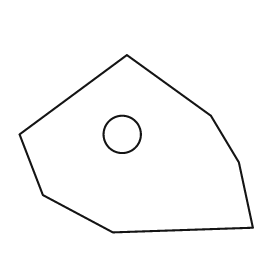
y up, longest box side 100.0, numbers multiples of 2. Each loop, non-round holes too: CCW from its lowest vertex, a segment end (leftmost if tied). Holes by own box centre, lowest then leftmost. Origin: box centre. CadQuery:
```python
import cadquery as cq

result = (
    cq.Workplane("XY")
    .moveTo(-10.0, -38.0)
    .lineTo(50.0, -36.0)
    .lineTo(44.0, -8.0)
    .lineTo(32.0, 12.0)
    .lineTo(-4.0, 38.0)
    .lineTo(-50.0, 4.0)
    .lineTo(-40.0, -22.0)
    .close()
    .moveTo(-6.0, 4.0)
    .circle(8.0)
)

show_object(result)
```